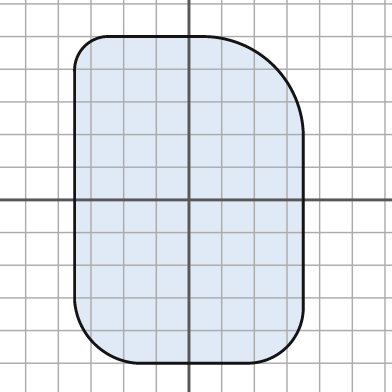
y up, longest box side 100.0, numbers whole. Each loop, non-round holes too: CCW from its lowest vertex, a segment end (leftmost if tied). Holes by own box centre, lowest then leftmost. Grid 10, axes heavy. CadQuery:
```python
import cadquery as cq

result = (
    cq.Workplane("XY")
    .moveTo(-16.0, -50.0)
    .lineTo(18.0, -50.0)
    .threePointArc((30.0, -45.0), (35.0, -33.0))
    .lineTo(35.0, 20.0)
    .threePointArc((26.0, 41.0), (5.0, 50.0))
    .lineTo(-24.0, 50.0)
    .threePointArc((-32.0, 47.0), (-35.0, 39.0))
    .lineTo(-35.0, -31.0)
    .threePointArc((-29.0, -44.0), (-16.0, -50.0))
    .close()
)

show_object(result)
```